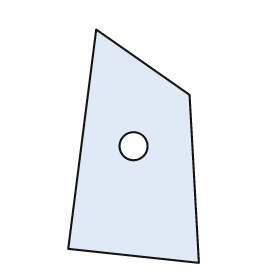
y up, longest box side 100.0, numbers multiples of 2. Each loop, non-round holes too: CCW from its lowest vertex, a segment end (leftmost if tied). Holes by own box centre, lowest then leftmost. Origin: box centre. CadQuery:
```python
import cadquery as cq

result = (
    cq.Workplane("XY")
    .moveTo(28.0, -50.0)
    .lineTo(24.0, 22.0)
    .lineTo(-16.0, 50.0)
    .lineTo(-28.0, -44.0)
    .close()
    .moveTo(0.0, 0.0)
    .circle(6.0)
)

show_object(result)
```